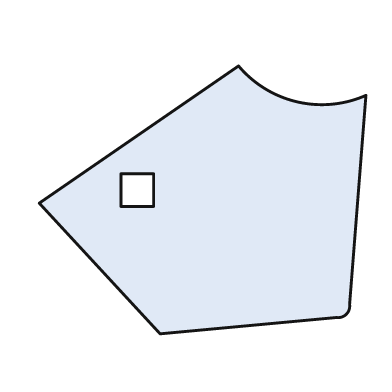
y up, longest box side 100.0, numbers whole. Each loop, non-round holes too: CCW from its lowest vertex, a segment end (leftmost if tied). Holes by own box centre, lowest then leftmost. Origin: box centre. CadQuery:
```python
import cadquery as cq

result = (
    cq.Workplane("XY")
    .moveTo(-13.0, -41.0)
    .lineTo(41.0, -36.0)
    .threePointArc((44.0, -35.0), (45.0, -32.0))
    .lineTo(50.0, 32.0)
    .threePointArc((29.0, 30.0), (11.0, 41.0))
    .lineTo(-50.0, -1.0)
    .close()
    .moveTo(-25.0, -2.0)
    .lineTo(-15.0, -2.0)
    .lineTo(-15.0, 8.0)
    .lineTo(-25.0, 8.0)
    .close()
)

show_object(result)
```